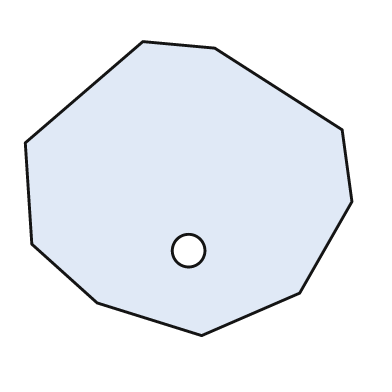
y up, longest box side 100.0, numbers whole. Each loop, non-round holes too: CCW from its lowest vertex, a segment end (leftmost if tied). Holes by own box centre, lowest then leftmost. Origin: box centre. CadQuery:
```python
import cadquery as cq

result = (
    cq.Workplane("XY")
    .moveTo(4.0, -45.0)
    .lineTo(34.0, -32.0)
    .lineTo(50.0, -4.0)
    .lineTo(47.0, 18.0)
    .lineTo(8.0, 43.0)
    .lineTo(-14.0, 45.0)
    .lineTo(-50.0, 14.0)
    .lineTo(-48.0, -17.0)
    .lineTo(-28.0, -35.0)
    .close()
    .moveTo(0.0, -19.0)
    .circle(5.0)
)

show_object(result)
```